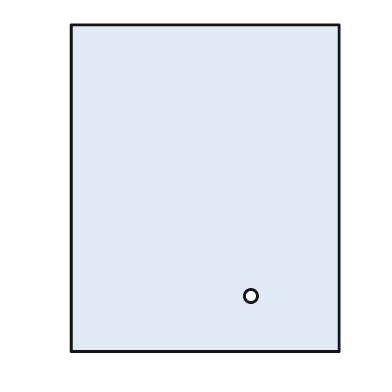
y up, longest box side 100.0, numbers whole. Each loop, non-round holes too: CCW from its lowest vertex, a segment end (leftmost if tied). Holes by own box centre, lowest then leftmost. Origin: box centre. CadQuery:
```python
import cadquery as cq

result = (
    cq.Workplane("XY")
    .moveTo(-41.0, -50.0)
    .lineTo(41.0, -50.0)
    .lineTo(41.0, 50.0)
    .lineTo(-41.0, 50.0)
    .close()
    .moveTo(14.0, -33.0)
    .circle(2.0)
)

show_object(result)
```